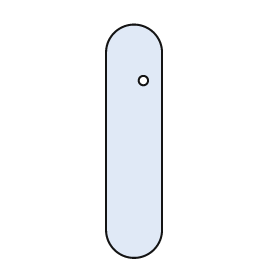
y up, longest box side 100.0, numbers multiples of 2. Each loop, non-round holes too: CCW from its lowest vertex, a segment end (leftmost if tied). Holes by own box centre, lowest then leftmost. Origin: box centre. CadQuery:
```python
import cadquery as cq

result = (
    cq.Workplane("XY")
    .moveTo(-12.0, -38.0)
    .threePointArc((0.0, -50.0), (12.0, -38.0))
    .lineTo(12.0, 38.0)
    .threePointArc((0.0, 50.0), (-12.0, 38.0))
    .close()
    .moveTo(4.0, 26.0)
    .circle(2.0)
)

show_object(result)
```